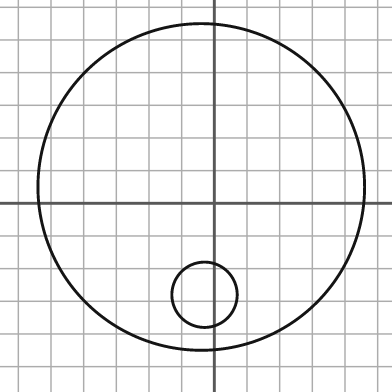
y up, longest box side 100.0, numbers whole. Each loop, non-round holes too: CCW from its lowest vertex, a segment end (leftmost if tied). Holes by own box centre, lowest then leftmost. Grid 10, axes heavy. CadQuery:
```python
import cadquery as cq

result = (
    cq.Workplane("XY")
    .moveTo(-4.0, 5.0)
    .circle(50.0)
    .moveTo(-3.0, -28.0)
    .circle(10.0)
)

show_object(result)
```